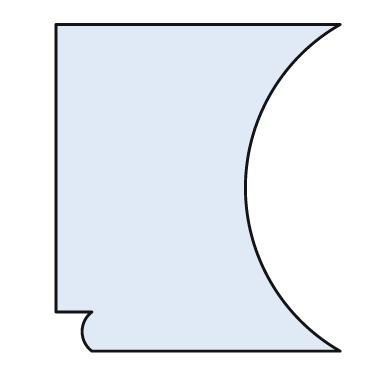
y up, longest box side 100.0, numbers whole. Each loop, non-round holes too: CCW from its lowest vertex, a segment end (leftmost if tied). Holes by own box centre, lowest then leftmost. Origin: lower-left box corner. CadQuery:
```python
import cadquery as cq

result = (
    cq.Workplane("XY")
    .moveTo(11.0, 0.0)
    .lineTo(87.0, 0.0)
    .threePointArc((58.0, 50.0), (87.0, 100.0))
    .lineTo(0.0, 100.0)
    .lineTo(0.0, 12.0)
    .lineTo(11.0, 12.0)
    .threePointArc((8.0, 6.0), (11.0, 0.0))
    .close()
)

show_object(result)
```